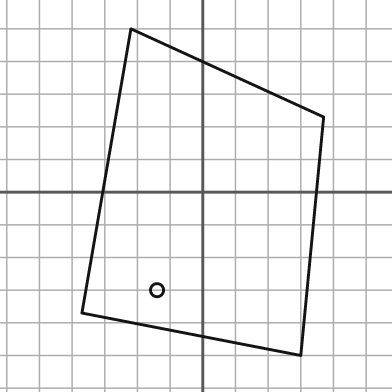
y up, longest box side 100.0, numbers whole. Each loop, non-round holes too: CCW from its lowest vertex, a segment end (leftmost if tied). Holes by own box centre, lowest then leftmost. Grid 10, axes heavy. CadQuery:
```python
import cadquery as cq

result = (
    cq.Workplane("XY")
    .moveTo(30.0, -50.0)
    .lineTo(37.0, 23.0)
    .lineTo(-22.0, 50.0)
    .lineTo(-37.0, -37.0)
    .close()
    .moveTo(-14.0, -30.0)
    .circle(2.0)
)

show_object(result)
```